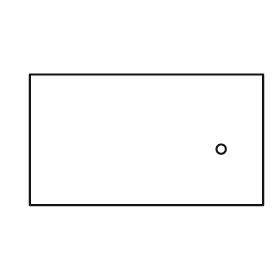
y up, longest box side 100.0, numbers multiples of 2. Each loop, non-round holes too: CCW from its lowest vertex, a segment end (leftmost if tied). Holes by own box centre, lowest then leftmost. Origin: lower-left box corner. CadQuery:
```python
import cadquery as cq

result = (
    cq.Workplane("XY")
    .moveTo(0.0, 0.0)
    .lineTo(100.0, 0.0)
    .lineTo(100.0, 56.0)
    .lineTo(0.0, 56.0)
    .close()
    .moveTo(82.0, 24.0)
    .circle(2.0)
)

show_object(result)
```